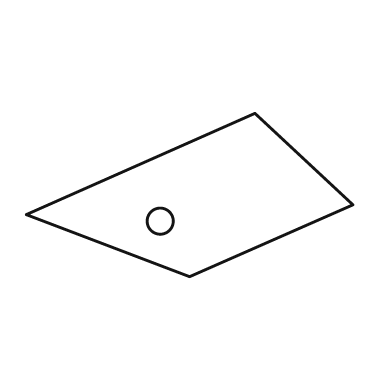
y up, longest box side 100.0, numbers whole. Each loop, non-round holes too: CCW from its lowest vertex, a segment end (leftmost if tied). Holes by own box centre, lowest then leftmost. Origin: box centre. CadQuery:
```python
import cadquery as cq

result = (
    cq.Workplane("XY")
    .moveTo(0.0, -25.0)
    .lineTo(50.0, -3.0)
    .lineTo(20.0, 25.0)
    .lineTo(-50.0, -6.0)
    .close()
    .moveTo(-9.0, -8.0)
    .circle(4.0)
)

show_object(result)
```